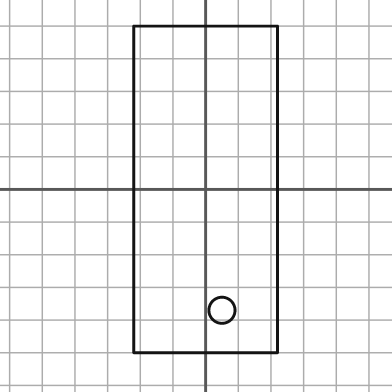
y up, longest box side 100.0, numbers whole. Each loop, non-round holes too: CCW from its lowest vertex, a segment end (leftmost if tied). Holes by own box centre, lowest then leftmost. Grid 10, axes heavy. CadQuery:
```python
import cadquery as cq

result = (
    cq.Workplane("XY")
    .moveTo(-22.0, -50.0)
    .lineTo(22.0, -50.0)
    .lineTo(22.0, 50.0)
    .lineTo(-22.0, 50.0)
    .close()
    .moveTo(5.0, -37.0)
    .circle(4.0)
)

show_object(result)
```